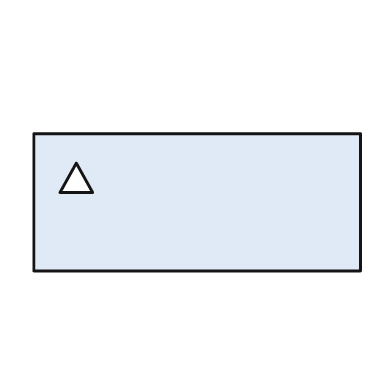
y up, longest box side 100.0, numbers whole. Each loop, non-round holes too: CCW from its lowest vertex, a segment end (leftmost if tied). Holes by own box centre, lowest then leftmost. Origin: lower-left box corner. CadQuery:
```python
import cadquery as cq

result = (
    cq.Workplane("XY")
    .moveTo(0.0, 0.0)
    .lineTo(100.0, 0.0)
    .lineTo(100.0, 42.0)
    .lineTo(0.0, 42.0)
    .close()
    .moveTo(8.0, 24.0)
    .lineTo(18.0, 24.0)
    .lineTo(13.0, 33.0)
    .close()
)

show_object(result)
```